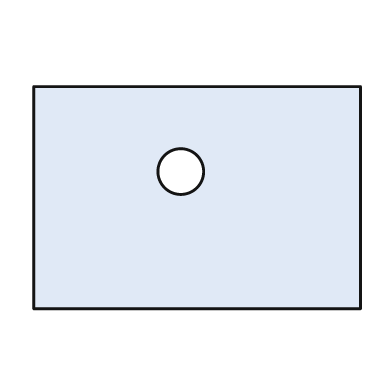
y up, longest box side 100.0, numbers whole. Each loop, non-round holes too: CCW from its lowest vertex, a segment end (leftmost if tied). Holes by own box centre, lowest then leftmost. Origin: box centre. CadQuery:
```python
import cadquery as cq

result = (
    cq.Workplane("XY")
    .moveTo(-50.0, -34.0)
    .lineTo(50.0, -34.0)
    .lineTo(50.0, 34.0)
    .lineTo(-50.0, 34.0)
    .close()
    .moveTo(-5.0, 8.0)
    .circle(7.0)
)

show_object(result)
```